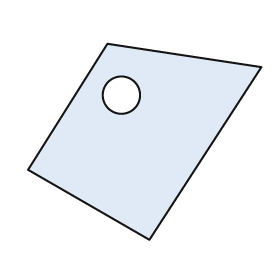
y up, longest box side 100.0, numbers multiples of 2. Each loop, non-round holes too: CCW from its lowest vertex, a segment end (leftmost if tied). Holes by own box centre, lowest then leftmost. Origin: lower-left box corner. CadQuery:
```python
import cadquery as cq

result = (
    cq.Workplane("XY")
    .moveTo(52.0, 0.0)
    .lineTo(100.0, 74.0)
    .lineTo(34.0, 84.0)
    .lineTo(0.0, 30.0)
    .close()
    .moveTo(40.0, 62.0)
    .circle(8.0)
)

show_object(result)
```